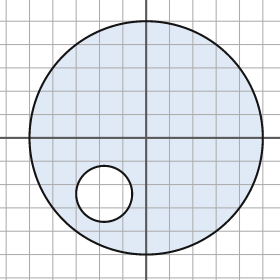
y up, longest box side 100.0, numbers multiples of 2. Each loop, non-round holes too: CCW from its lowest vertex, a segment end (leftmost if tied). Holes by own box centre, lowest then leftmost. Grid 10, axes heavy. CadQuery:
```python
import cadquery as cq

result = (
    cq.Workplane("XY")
    .moveTo(0.0, 0.0)
    .circle(50.0)
    .moveTo(-18.0, -24.0)
    .circle(12.0)
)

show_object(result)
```